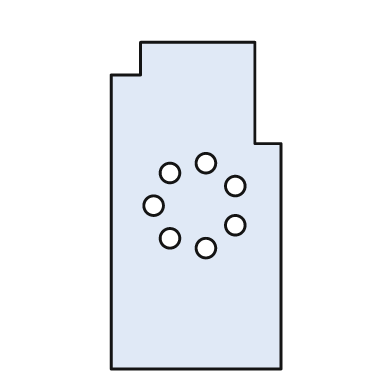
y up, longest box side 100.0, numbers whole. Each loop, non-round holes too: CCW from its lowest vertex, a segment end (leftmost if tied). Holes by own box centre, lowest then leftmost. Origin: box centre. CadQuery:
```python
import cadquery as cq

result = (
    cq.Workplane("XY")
    .moveTo(-26.0, -50.0)
    .lineTo(26.0, -50.0)
    .lineTo(26.0, 19.0)
    .lineTo(18.0, 19.0)
    .lineTo(18.0, 50.0)
    .lineTo(-17.0, 50.0)
    .lineTo(-17.0, 40.0)
    .lineTo(-26.0, 40.0)
    .close()
    .moveTo(3.0, -13.0)
    .circle(3.0)
    .moveTo(-8.0, -10.0)
    .circle(3.0)
    .moveTo(12.0, -6.0)
    .circle(3.0)
    .moveTo(-13.0, 0.0)
    .circle(3.0)
    .moveTo(12.0, 6.0)
    .circle(3.0)
    .moveTo(-8.0, 10.0)
    .circle(3.0)
    .moveTo(3.0, 13.0)
    .circle(3.0)
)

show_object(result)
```